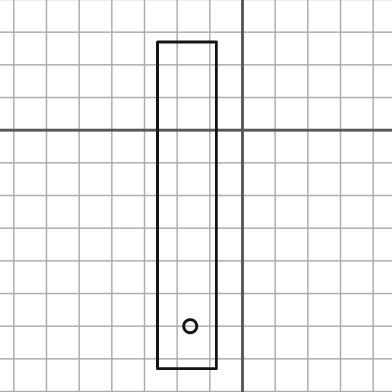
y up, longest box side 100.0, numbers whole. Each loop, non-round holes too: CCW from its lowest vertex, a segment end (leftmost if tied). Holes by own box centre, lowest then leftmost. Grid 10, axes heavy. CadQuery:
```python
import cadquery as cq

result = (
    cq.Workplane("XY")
    .moveTo(-26.0, -73.0)
    .lineTo(-8.0, -73.0)
    .lineTo(-8.0, 27.0)
    .lineTo(-26.0, 27.0)
    .close()
    .moveTo(-16.0, -60.0)
    .circle(2.0)
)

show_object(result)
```